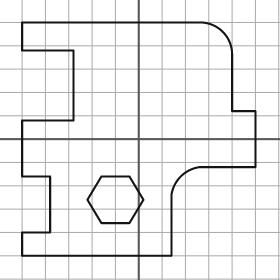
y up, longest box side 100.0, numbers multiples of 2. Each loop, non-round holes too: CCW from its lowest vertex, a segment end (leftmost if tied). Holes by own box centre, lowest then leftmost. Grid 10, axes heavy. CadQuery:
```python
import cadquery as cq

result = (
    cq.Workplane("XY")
    .moveTo(-50.0, -50.0)
    .lineTo(14.0, -50.0)
    .lineTo(14.0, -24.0)
    .threePointArc((18.0, -16.0), (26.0, -12.0))
    .lineTo(50.0, -12.0)
    .lineTo(50.0, 12.0)
    .lineTo(40.0, 12.0)
    .lineTo(40.0, 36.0)
    .threePointArc((36.0, 46.0), (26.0, 50.0))
    .lineTo(-50.0, 50.0)
    .lineTo(-50.0, 38.0)
    .lineTo(-28.0, 38.0)
    .lineTo(-28.0, 8.0)
    .lineTo(-50.0, 8.0)
    .lineTo(-50.0, -16.0)
    .lineTo(-38.0, -16.0)
    .lineTo(-38.0, -40.0)
    .lineTo(-50.0, -40.0)
    .close()
    .moveTo(-16.0, -36.0)
    .lineTo(-4.0, -36.0)
    .lineTo(2.0, -26.0)
    .lineTo(-4.0, -16.0)
    .lineTo(-16.0, -16.0)
    .lineTo(-22.0, -26.0)
    .close()
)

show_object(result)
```